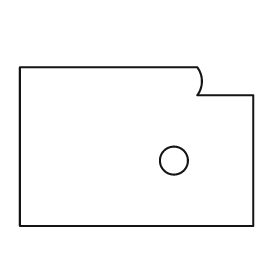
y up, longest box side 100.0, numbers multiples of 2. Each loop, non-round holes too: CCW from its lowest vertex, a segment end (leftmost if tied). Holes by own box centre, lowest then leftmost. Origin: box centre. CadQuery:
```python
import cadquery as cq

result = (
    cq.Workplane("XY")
    .moveTo(-50.0, -34.0)
    .lineTo(50.0, -34.0)
    .lineTo(50.0, 22.0)
    .lineTo(26.0, 22.0)
    .threePointArc((28.0, 28.0), (26.0, 34.0))
    .lineTo(-50.0, 34.0)
    .close()
    .moveTo(16.0, -6.0)
    .circle(6.0)
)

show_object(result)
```